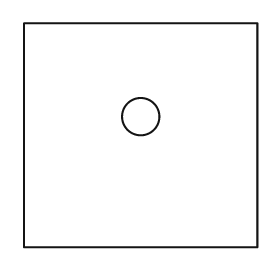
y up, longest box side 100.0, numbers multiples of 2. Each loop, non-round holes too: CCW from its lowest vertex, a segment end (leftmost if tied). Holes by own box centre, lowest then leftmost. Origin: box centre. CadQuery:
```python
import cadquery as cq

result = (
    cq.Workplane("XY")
    .moveTo(-50.0, -48.0)
    .lineTo(50.0, -48.0)
    .lineTo(50.0, 48.0)
    .lineTo(-50.0, 48.0)
    .close()
    .moveTo(0.0, 8.0)
    .circle(8.0)
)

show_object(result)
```